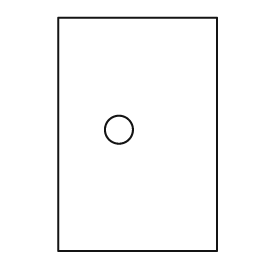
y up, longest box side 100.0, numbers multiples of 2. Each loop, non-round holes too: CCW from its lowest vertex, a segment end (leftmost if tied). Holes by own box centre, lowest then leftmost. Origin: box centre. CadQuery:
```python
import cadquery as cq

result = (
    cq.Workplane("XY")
    .moveTo(-34.0, -50.0)
    .lineTo(34.0, -50.0)
    .lineTo(34.0, 50.0)
    .lineTo(-34.0, 50.0)
    .close()
    .moveTo(-8.0, 2.0)
    .circle(6.0)
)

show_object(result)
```